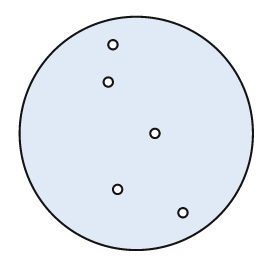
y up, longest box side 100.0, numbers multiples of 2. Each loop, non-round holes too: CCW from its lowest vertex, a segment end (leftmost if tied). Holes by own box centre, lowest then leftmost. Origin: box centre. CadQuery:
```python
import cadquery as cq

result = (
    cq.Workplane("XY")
    .moveTo(0.0, 0.0)
    .circle(50.0)
    .moveTo(20.0, -34.0)
    .circle(2.0)
    .moveTo(-8.0, -24.0)
    .circle(2.0)
    .moveTo(8.0, 0.0)
    .circle(2.0)
    .moveTo(-12.0, 22.0)
    .circle(2.0)
    .moveTo(-10.0, 38.0)
    .circle(2.0)
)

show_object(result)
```